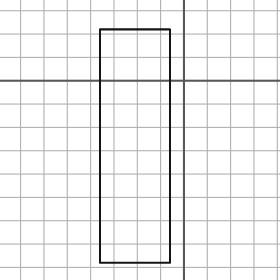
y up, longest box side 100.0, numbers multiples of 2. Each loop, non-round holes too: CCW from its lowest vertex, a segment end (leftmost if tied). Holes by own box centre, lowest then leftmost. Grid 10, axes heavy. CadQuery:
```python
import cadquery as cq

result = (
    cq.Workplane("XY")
    .moveTo(-36.0, -78.0)
    .lineTo(-6.0, -78.0)
    .lineTo(-6.0, 22.0)
    .lineTo(-36.0, 22.0)
    .close()
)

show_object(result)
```